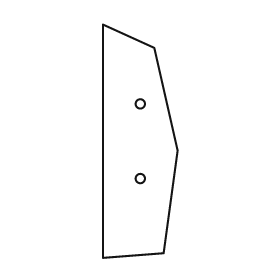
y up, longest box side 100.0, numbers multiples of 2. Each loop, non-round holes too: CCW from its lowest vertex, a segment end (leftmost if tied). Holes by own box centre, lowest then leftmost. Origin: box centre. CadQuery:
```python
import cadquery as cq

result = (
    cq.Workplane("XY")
    .moveTo(-16.0, -50.0)
    .lineTo(10.0, -48.0)
    .lineTo(16.0, -4.0)
    .lineTo(6.0, 40.0)
    .lineTo(-16.0, 50.0)
    .close()
    .moveTo(0.0, -16.0)
    .circle(2.0)
    .moveTo(0.0, 16.0)
    .circle(2.0)
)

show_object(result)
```